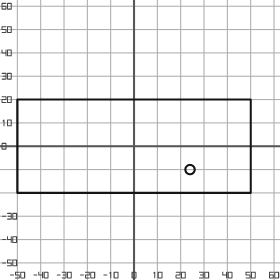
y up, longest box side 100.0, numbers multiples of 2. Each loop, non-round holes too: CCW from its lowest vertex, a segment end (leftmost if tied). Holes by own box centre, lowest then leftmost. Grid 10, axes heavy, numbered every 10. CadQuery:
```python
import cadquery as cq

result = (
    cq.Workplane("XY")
    .moveTo(-50.0, -20.0)
    .lineTo(50.0, -20.0)
    .lineTo(50.0, 20.0)
    .lineTo(-50.0, 20.0)
    .close()
    .moveTo(24.0, -10.0)
    .circle(2.0)
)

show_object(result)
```